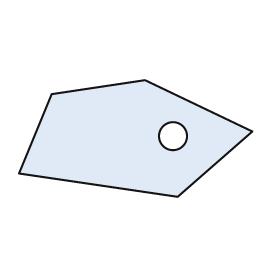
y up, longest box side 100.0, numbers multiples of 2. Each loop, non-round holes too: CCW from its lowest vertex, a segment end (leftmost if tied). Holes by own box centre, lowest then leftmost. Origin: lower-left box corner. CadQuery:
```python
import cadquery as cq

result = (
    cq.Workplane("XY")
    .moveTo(68.0, 0.0)
    .lineTo(100.0, 28.0)
    .lineTo(54.0, 50.0)
    .lineTo(14.0, 44.0)
    .lineTo(0.0, 10.0)
    .close()
    .moveTo(66.0, 26.0)
    .circle(6.0)
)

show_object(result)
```